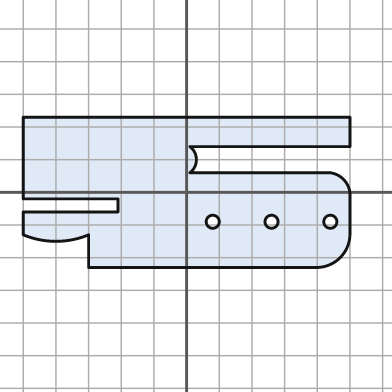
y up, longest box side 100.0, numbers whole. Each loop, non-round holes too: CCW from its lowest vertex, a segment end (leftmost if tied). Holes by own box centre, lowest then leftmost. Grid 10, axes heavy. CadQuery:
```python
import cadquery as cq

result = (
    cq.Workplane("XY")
    .moveTo(-30.0, -23.0)
    .lineTo(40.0, -23.0)
    .threePointArc((47.0, -20.0), (50.0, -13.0))
    .lineTo(50.0, 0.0)
    .threePointArc((48.0, 4.0), (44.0, 6.0))
    .lineTo(1.0, 6.0)
    .threePointArc((3.0, 10.0), (1.0, 14.0))
    .lineTo(50.0, 14.0)
    .lineTo(50.0, 23.0)
    .lineTo(-50.0, 23.0)
    .lineTo(-50.0, -2.0)
    .lineTo(-21.0, -2.0)
    .lineTo(-21.0, -6.0)
    .lineTo(-50.0, -6.0)
    .lineTo(-50.0, -13.0)
    .threePointArc((-40.0, -15.0), (-30.0, -13.0))
    .close()
    .moveTo(8.0, -9.0)
    .circle(2.0)
    .moveTo(26.0, -9.0)
    .circle(2.0)
    .moveTo(44.0, -9.0)
    .circle(2.0)
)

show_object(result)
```